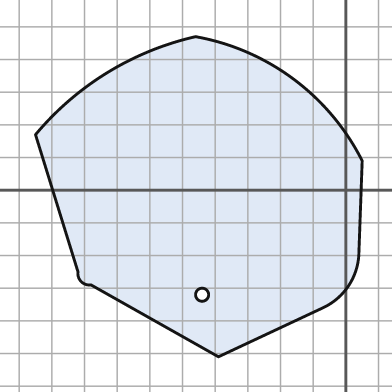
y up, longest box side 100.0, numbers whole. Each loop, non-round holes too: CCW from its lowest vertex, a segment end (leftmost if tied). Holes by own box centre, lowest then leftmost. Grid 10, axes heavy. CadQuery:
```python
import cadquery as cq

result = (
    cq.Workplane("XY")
    .moveTo(-39.0, -51.0)
    .lineTo(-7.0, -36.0)
    .threePointArc((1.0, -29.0), (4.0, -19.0))
    .lineTo(5.0, 9.0)
    .threePointArc((-16.0, 34.0), (-46.0, 47.0))
    .threePointArc((-73.0, 36.0), (-95.0, 17.0))
    .lineTo(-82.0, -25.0)
    .threePointArc((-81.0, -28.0), (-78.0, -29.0))
    .close()
    .moveTo(-44.0, -32.0)
    .circle(2.0)
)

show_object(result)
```